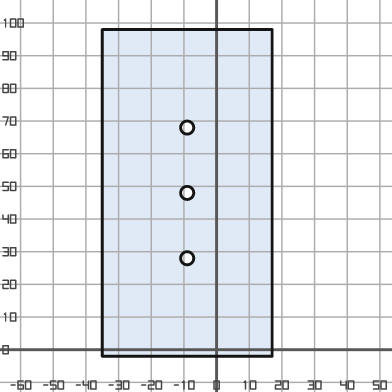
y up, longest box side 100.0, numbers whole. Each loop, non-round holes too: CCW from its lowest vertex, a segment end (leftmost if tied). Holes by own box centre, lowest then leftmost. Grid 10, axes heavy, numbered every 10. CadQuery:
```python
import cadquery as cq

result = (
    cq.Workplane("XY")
    .moveTo(-35.0, -2.0)
    .lineTo(17.0, -2.0)
    .lineTo(17.0, 98.0)
    .lineTo(-35.0, 98.0)
    .close()
    .moveTo(-9.0, 28.0)
    .circle(2.0)
    .moveTo(-9.0, 48.0)
    .circle(2.0)
    .moveTo(-9.0, 68.0)
    .circle(2.0)
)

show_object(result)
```